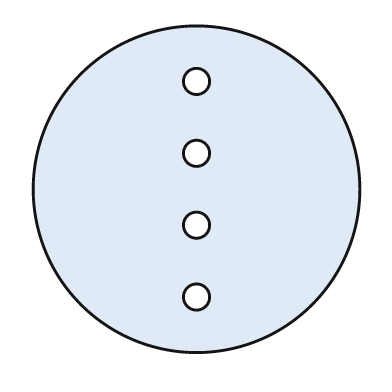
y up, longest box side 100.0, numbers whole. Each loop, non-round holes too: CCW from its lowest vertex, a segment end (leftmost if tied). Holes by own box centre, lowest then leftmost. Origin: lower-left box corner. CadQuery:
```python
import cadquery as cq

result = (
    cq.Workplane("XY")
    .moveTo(50.0, 50.0)
    .circle(50.0)
    .moveTo(50.0, 17.0)
    .circle(4.0)
    .moveTo(50.0, 39.0)
    .circle(4.0)
    .moveTo(50.0, 61.0)
    .circle(4.0)
    .moveTo(50.0, 83.0)
    .circle(4.0)
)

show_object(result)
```